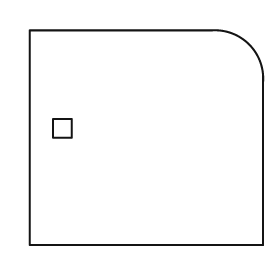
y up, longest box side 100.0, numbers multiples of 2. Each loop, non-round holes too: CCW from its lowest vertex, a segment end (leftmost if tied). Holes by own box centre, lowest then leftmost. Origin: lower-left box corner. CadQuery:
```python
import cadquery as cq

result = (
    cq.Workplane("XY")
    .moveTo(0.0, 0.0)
    .lineTo(100.0, 0.0)
    .lineTo(100.0, 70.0)
    .threePointArc((94.0, 86.0), (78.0, 92.0))
    .lineTo(0.0, 92.0)
    .close()
    .moveTo(10.0, 46.0)
    .lineTo(18.0, 46.0)
    .lineTo(18.0, 54.0)
    .lineTo(10.0, 54.0)
    .close()
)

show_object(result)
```